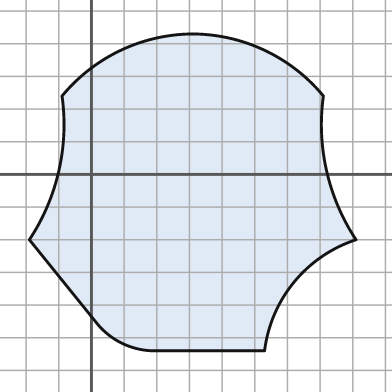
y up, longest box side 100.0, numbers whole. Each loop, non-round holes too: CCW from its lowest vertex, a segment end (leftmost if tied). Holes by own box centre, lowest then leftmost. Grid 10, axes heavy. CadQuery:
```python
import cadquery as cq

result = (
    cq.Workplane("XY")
    .moveTo(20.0, -54.0)
    .lineTo(53.0, -54.0)
    .threePointArc((62.0, -33.0), (81.0, -20.0))
    .threePointArc((72.0, 1.0), (71.0, 24.0))
    .threePointArc((53.0, 38.0), (31.0, 43.0))
    .threePointArc((9.0, 38.0), (-9.0, 24.0))
    .threePointArc((-10.0, 1.0), (-19.0, -20.0))
    .lineTo(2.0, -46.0)
    .threePointArc((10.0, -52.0), (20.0, -54.0))
    .close()
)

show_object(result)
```